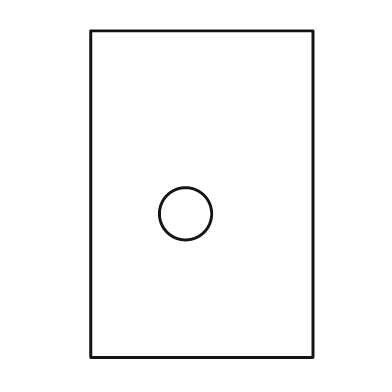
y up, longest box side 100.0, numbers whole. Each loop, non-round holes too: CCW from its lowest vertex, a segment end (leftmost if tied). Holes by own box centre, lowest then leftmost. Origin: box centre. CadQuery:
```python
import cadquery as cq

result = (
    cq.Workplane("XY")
    .moveTo(-34.0, -50.0)
    .lineTo(34.0, -50.0)
    .lineTo(34.0, 50.0)
    .lineTo(-34.0, 50.0)
    .close()
    .moveTo(-5.0, -6.0)
    .circle(8.0)
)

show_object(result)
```